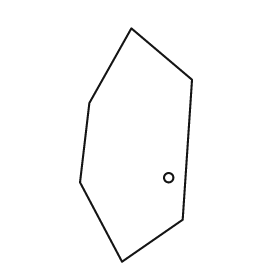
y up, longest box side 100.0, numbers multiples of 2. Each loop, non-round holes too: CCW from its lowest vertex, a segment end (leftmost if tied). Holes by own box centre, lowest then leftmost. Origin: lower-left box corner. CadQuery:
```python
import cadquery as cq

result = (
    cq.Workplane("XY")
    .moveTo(18.0, 0.0)
    .lineTo(44.0, 18.0)
    .lineTo(48.0, 78.0)
    .lineTo(22.0, 100.0)
    .lineTo(4.0, 68.0)
    .lineTo(0.0, 34.0)
    .close()
    .moveTo(38.0, 36.0)
    .circle(2.0)
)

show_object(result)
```